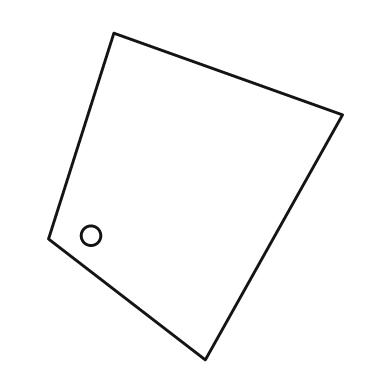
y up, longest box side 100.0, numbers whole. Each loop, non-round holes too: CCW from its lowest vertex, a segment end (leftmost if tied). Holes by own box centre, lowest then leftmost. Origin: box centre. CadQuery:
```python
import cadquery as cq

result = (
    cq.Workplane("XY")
    .moveTo(3.0, -50.0)
    .lineTo(45.0, 25.0)
    .lineTo(-25.0, 50.0)
    .lineTo(-45.0, -13.0)
    .close()
    .moveTo(-32.0, -12.0)
    .circle(3.0)
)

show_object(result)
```